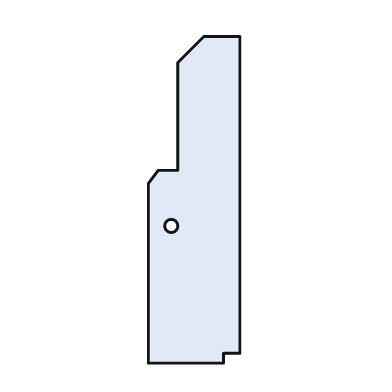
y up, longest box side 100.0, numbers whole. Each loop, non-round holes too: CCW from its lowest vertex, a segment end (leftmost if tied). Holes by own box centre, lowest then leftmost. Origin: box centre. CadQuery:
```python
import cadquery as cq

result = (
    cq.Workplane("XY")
    .moveTo(-14.0, -50.0)
    .lineTo(9.0, -50.0)
    .lineTo(9.0, -47.0)
    .lineTo(14.0, -47.0)
    .lineTo(14.0, 50.0)
    .lineTo(3.0, 50.0)
    .lineTo(-5.0, 42.0)
    .lineTo(-5.0, 9.0)
    .lineTo(-11.0, 9.0)
    .lineTo(-14.0, 5.0)
    .close()
    .moveTo(-7.0, -8.0)
    .circle(2.0)
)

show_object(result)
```